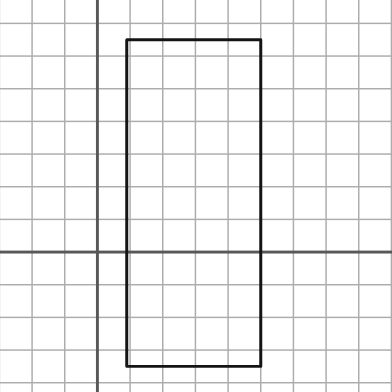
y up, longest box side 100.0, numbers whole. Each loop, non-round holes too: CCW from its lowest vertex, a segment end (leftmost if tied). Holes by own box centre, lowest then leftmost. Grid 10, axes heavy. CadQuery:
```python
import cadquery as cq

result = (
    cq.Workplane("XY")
    .moveTo(9.0, -35.0)
    .lineTo(50.0, -35.0)
    .lineTo(50.0, 65.0)
    .lineTo(9.0, 65.0)
    .close()
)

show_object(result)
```